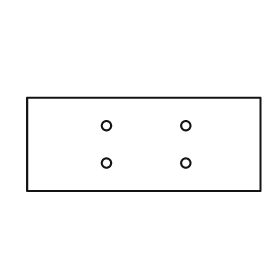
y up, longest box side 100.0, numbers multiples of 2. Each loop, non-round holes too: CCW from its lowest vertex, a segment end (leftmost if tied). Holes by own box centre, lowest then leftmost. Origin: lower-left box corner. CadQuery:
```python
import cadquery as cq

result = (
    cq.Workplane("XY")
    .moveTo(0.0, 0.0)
    .lineTo(100.0, 0.0)
    .lineTo(100.0, 40.0)
    .lineTo(0.0, 40.0)
    .close()
    .moveTo(34.0, 12.0)
    .circle(2.0)
    .moveTo(68.0, 12.0)
    .circle(2.0)
    .moveTo(34.0, 28.0)
    .circle(2.0)
    .moveTo(68.0, 28.0)
    .circle(2.0)
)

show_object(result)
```